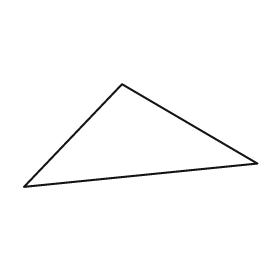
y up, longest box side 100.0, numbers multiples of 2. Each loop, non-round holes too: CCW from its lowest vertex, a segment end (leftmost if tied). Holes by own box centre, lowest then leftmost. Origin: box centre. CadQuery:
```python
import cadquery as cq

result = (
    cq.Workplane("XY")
    .moveTo(-50.0, -22.0)
    .lineTo(50.0, -12.0)
    .lineTo(-8.0, 22.0)
    .close()
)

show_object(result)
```